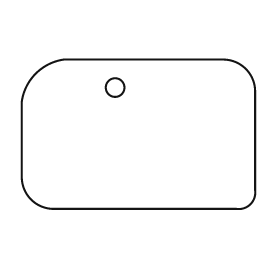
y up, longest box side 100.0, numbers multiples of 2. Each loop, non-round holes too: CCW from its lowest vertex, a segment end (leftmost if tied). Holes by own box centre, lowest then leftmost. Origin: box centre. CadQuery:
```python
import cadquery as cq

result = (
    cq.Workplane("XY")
    .moveTo(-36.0, -32.0)
    .lineTo(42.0, -32.0)
    .threePointArc((48.0, -30.0), (50.0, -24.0))
    .lineTo(50.0, 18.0)
    .threePointArc((46.0, 28.0), (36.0, 32.0))
    .lineTo(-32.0, 32.0)
    .threePointArc((-44.0, 26.0), (-50.0, 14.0))
    .lineTo(-50.0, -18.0)
    .threePointArc((-46.0, -28.0), (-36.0, -32.0))
    .close()
    .moveTo(-10.0, 20.0)
    .circle(4.0)
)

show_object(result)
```